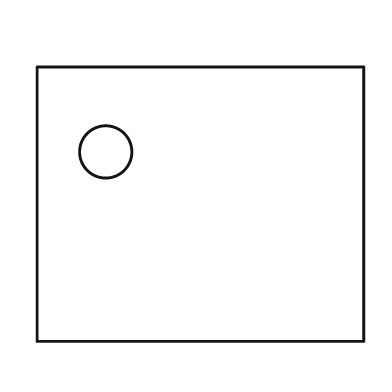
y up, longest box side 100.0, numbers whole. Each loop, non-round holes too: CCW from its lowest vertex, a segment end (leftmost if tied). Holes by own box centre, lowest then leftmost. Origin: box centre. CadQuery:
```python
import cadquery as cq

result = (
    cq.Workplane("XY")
    .moveTo(-50.0, -42.0)
    .lineTo(50.0, -42.0)
    .lineTo(50.0, 42.0)
    .lineTo(-50.0, 42.0)
    .close()
    .moveTo(-29.0, 16.0)
    .circle(8.0)
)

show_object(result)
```